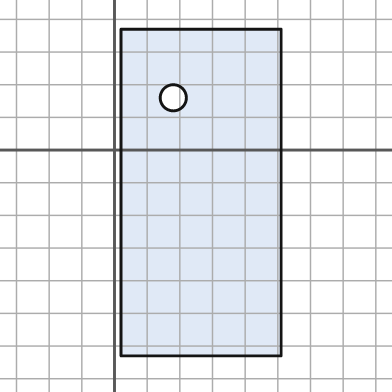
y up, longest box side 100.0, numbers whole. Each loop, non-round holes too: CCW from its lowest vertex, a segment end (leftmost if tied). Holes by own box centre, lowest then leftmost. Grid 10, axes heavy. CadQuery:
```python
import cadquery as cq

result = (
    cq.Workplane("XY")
    .moveTo(2.0, -63.0)
    .lineTo(51.0, -63.0)
    .lineTo(51.0, 37.0)
    .lineTo(2.0, 37.0)
    .close()
    .moveTo(18.0, 16.0)
    .circle(4.0)
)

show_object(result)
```